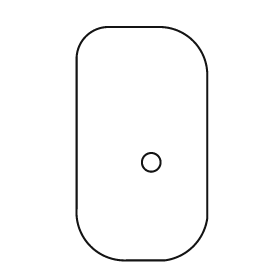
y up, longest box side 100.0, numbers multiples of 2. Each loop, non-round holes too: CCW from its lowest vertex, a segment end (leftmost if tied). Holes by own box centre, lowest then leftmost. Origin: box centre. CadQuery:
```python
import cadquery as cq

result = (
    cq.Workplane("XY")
    .moveTo(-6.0, -50.0)
    .lineTo(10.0, -50.0)
    .threePointArc((22.0, -44.0), (28.0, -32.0))
    .lineTo(28.0, 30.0)
    .threePointArc((22.0, 44.0), (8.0, 50.0))
    .lineTo(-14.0, 50.0)
    .threePointArc((-24.0, 46.0), (-28.0, 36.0))
    .lineTo(-28.0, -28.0)
    .threePointArc((-22.0, -44.0), (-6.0, -50.0))
    .close()
    .moveTo(4.0, -8.0)
    .circle(4.0)
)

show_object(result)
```